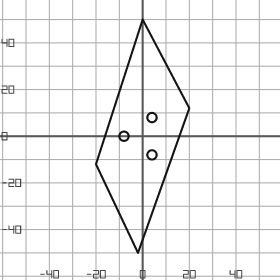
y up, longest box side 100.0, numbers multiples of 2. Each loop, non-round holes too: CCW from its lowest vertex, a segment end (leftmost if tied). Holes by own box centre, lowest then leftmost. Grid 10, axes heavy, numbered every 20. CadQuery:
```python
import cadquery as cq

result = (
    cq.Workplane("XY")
    .moveTo(-2.0, -50.0)
    .lineTo(20.0, 12.0)
    .lineTo(0.0, 50.0)
    .lineTo(-20.0, -12.0)
    .close()
    .moveTo(4.0, -8.0)
    .circle(2.0)
    .moveTo(-8.0, 0.0)
    .circle(2.0)
    .moveTo(4.0, 8.0)
    .circle(2.0)
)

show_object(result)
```